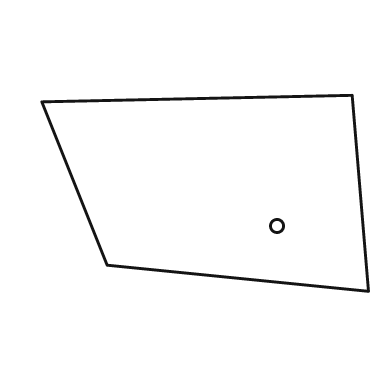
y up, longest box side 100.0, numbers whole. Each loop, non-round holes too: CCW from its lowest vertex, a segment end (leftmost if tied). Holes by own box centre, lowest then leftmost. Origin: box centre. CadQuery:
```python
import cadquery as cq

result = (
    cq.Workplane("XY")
    .moveTo(50.0, -30.0)
    .lineTo(45.0, 30.0)
    .lineTo(-50.0, 28.0)
    .lineTo(-30.0, -22.0)
    .close()
    .moveTo(22.0, -10.0)
    .circle(2.0)
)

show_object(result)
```